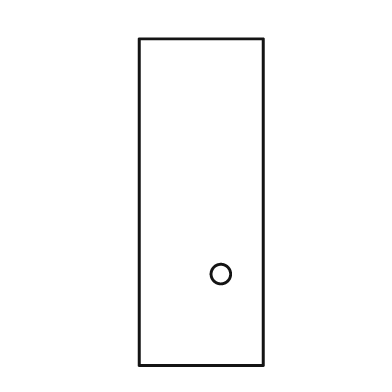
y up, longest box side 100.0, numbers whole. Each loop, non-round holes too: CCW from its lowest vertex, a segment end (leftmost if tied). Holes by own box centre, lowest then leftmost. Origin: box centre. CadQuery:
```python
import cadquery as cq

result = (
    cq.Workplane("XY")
    .moveTo(-19.0, -50.0)
    .lineTo(19.0, -50.0)
    .lineTo(19.0, 50.0)
    .lineTo(-19.0, 50.0)
    .close()
    .moveTo(6.0, -22.0)
    .circle(3.0)
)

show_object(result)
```